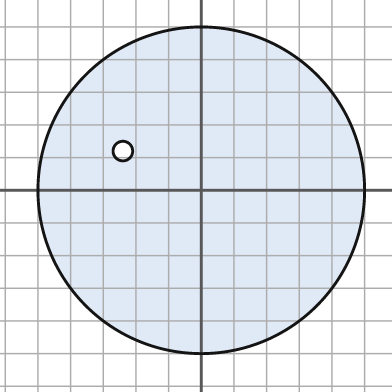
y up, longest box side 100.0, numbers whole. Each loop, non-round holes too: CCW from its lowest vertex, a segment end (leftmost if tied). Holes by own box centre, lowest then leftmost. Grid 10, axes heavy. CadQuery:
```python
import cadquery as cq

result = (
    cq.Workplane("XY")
    .moveTo(0.0, 0.0)
    .circle(50.0)
    .moveTo(-24.0, 12.0)
    .circle(3.0)
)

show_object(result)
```